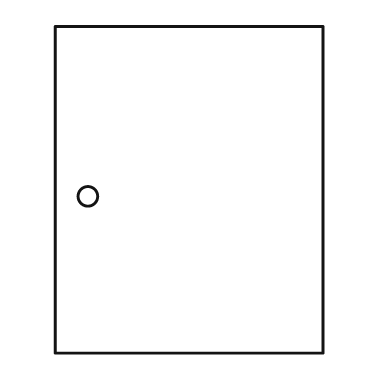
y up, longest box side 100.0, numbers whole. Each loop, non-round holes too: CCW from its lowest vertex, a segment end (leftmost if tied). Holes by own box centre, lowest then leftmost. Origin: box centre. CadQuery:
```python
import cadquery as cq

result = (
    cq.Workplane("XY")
    .moveTo(-41.0, -50.0)
    .lineTo(41.0, -50.0)
    .lineTo(41.0, 50.0)
    .lineTo(-41.0, 50.0)
    .close()
    .moveTo(-31.0, -2.0)
    .circle(3.0)
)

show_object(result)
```